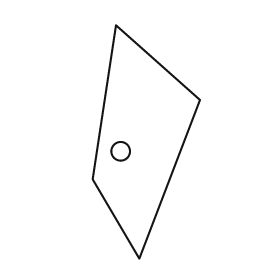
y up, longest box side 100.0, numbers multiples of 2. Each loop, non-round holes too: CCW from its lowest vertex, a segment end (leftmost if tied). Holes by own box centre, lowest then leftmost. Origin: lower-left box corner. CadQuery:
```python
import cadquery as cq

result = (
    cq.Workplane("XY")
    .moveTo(20.0, 0.0)
    .lineTo(46.0, 68.0)
    .lineTo(10.0, 100.0)
    .lineTo(0.0, 34.0)
    .close()
    .moveTo(12.0, 46.0)
    .circle(4.0)
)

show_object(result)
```